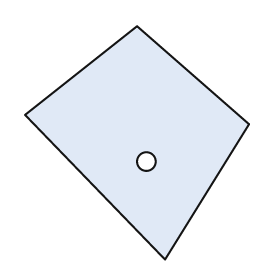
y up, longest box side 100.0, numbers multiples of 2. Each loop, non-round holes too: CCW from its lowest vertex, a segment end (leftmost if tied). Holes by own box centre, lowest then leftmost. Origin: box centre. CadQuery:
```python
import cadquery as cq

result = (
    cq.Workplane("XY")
    .moveTo(12.0, -50.0)
    .lineTo(48.0, 8.0)
    .lineTo(0.0, 50.0)
    .lineTo(-48.0, 12.0)
    .close()
    .moveTo(4.0, -8.0)
    .circle(4.0)
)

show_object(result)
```